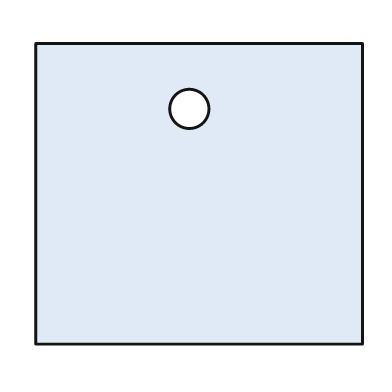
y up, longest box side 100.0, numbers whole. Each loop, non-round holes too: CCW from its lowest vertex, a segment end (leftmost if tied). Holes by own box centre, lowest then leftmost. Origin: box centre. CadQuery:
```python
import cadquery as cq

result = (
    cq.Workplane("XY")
    .moveTo(-50.0, -46.0)
    .lineTo(50.0, -46.0)
    .lineTo(50.0, 46.0)
    .lineTo(-50.0, 46.0)
    .close()
    .moveTo(-3.0, 26.0)
    .circle(6.0)
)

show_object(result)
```